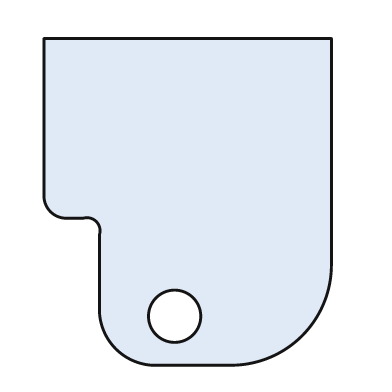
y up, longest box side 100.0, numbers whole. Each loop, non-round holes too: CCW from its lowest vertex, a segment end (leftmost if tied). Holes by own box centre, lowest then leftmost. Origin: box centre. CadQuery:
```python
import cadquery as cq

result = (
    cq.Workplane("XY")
    .moveTo(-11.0, -50.0)
    .lineTo(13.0, -50.0)
    .threePointArc((35.0, -41.0), (44.0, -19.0))
    .lineTo(44.0, 50.0)
    .lineTo(-44.0, 50.0)
    .lineTo(-44.0, 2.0)
    .threePointArc((-42.0, -3.0), (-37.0, -5.0))
    .lineTo(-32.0, -5.0)
    .threePointArc((-28.0, -6.0), (-27.0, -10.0))
    .lineTo(-27.0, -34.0)
    .threePointArc((-22.0, -45.0), (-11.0, -50.0))
    .close()
    .moveTo(-4.0, -35.0)
    .circle(8.0)
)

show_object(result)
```